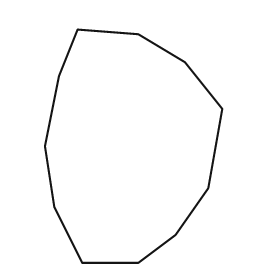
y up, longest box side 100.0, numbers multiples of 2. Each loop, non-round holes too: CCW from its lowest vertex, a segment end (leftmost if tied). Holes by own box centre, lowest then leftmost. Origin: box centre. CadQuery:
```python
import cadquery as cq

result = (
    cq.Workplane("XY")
    .moveTo(-22.0, -50.0)
    .lineTo(2.0, -50.0)
    .lineTo(18.0, -38.0)
    .lineTo(32.0, -18.0)
    .lineTo(38.0, 16.0)
    .lineTo(22.0, 36.0)
    .lineTo(2.0, 48.0)
    .lineTo(-24.0, 50.0)
    .lineTo(-32.0, 30.0)
    .lineTo(-38.0, 0.0)
    .lineTo(-34.0, -26.0)
    .close()
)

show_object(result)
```